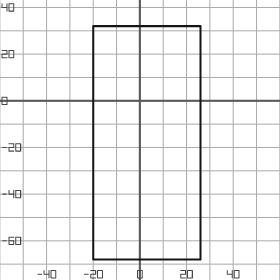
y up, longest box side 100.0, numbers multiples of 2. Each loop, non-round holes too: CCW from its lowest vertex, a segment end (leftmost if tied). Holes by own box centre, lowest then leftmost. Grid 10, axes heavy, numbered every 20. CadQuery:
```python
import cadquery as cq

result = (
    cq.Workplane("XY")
    .moveTo(-20.0, -68.0)
    .lineTo(26.0, -68.0)
    .lineTo(26.0, 32.0)
    .lineTo(-20.0, 32.0)
    .close()
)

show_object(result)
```